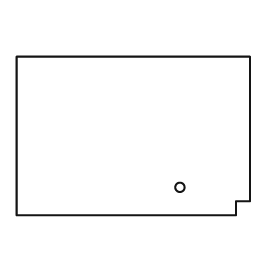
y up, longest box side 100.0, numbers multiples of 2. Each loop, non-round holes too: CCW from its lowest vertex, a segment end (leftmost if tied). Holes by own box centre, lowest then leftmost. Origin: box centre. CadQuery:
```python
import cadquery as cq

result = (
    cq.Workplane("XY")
    .moveTo(-50.0, -34.0)
    .lineTo(44.0, -34.0)
    .lineTo(44.0, -28.0)
    .lineTo(50.0, -28.0)
    .lineTo(50.0, 34.0)
    .lineTo(-50.0, 34.0)
    .close()
    .moveTo(20.0, -22.0)
    .circle(2.0)
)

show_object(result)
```